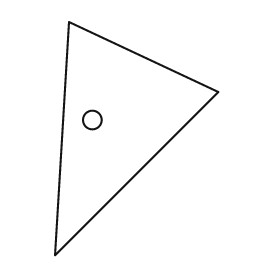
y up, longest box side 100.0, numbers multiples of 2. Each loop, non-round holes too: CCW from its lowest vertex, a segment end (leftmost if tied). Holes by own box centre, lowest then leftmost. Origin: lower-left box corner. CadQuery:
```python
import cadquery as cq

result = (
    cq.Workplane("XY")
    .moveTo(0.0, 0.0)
    .lineTo(70.0, 70.0)
    .lineTo(6.0, 100.0)
    .close()
    .moveTo(16.0, 58.0)
    .circle(4.0)
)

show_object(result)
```